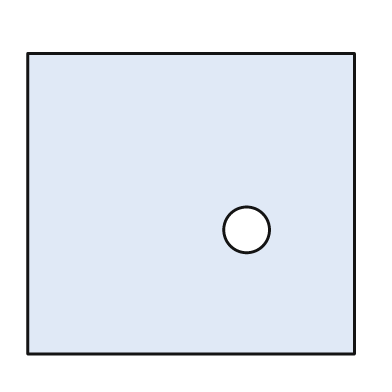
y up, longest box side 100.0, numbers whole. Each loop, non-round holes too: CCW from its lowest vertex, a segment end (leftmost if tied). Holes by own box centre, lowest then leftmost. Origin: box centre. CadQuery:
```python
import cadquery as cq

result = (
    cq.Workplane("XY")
    .moveTo(-50.0, -46.0)
    .lineTo(50.0, -46.0)
    .lineTo(50.0, 46.0)
    .lineTo(-50.0, 46.0)
    .close()
    .moveTo(17.0, -8.0)
    .circle(7.0)
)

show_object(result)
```